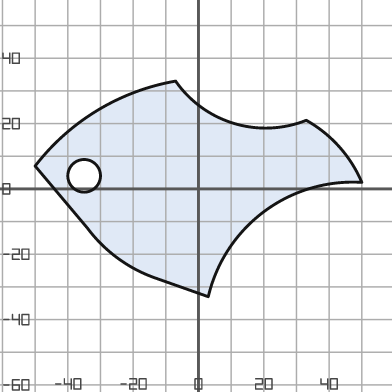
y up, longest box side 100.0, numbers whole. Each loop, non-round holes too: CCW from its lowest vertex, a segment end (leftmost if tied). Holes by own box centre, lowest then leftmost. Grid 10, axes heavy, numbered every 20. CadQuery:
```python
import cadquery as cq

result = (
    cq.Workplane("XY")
    .moveTo(3.0, -33.0)
    .threePointArc((20.0, -7.0), (50.0, 2.0))
    .threePointArc((43.0, 13.0), (33.0, 21.0))
    .threePointArc((11.0, 20.0), (-7.0, 33.0))
    .threePointArc((-31.0, 24.0), (-50.0, 7.0))
    .lineTo(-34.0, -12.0)
    .threePointArc((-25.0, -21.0), (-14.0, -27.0))
    .close()
    .moveTo(-35.0, 4.0)
    .circle(5.0)
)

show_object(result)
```